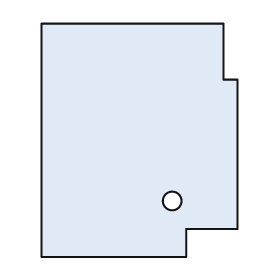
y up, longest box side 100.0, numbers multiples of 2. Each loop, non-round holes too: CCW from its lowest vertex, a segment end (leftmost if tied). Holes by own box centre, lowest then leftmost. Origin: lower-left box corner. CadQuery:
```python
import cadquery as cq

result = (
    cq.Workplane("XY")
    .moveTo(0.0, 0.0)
    .lineTo(62.0, 0.0)
    .lineTo(62.0, 12.0)
    .lineTo(84.0, 12.0)
    .lineTo(84.0, 76.0)
    .lineTo(78.0, 76.0)
    .lineTo(78.0, 100.0)
    .lineTo(0.0, 100.0)
    .close()
    .moveTo(56.0, 24.0)
    .circle(4.0)
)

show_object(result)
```